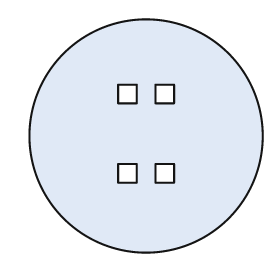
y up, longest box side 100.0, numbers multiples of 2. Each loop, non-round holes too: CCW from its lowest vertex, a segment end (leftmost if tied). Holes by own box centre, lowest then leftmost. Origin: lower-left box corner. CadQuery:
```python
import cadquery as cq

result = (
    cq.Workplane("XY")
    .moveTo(50.0, 50.0)
    .circle(50.0)
    .moveTo(38.0, 30.0)
    .lineTo(46.0, 30.0)
    .lineTo(46.0, 38.0)
    .lineTo(38.0, 38.0)
    .close()
    .moveTo(54.0, 30.0)
    .lineTo(62.0, 30.0)
    .lineTo(62.0, 38.0)
    .lineTo(54.0, 38.0)
    .close()
    .moveTo(38.0, 64.0)
    .lineTo(46.0, 64.0)
    .lineTo(46.0, 72.0)
    .lineTo(38.0, 72.0)
    .close()
    .moveTo(54.0, 64.0)
    .lineTo(62.0, 64.0)
    .lineTo(62.0, 72.0)
    .lineTo(54.0, 72.0)
    .close()
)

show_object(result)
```